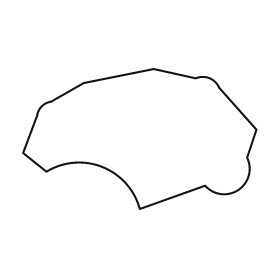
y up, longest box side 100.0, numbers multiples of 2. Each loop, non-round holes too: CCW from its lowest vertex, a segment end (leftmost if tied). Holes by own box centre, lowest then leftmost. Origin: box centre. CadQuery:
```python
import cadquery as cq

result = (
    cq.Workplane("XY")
    .moveTo(0.0, -30.0)
    .lineTo(28.0, -20.0)
    .threePointArc((42.0, -22.0), (46.0, -8.0))
    .lineTo(50.0, 4.0)
    .lineTo(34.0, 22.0)
    .threePointArc((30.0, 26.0), (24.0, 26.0))
    .lineTo(6.0, 30.0)
    .lineTo(-24.0, 24.0)
    .lineTo(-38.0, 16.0)
    .threePointArc((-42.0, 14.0), (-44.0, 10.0))
    .lineTo(-50.0, -6.0)
    .lineTo(-40.0, -14.0)
    .threePointArc((-16.0, -12.0), (0.0, -30.0))
    .close()
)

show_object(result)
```